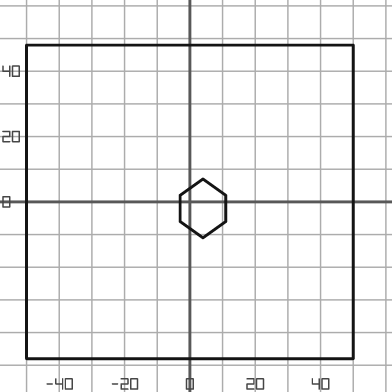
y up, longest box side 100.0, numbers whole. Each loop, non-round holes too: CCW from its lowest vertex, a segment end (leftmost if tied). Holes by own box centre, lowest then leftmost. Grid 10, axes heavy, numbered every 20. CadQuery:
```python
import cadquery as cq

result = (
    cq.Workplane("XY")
    .moveTo(-50.0, -48.0)
    .lineTo(50.0, -48.0)
    .lineTo(50.0, 48.0)
    .lineTo(-50.0, 48.0)
    .close()
    .moveTo(4.0, -11.0)
    .lineTo(11.0, -6.0)
    .lineTo(11.0, 2.0)
    .lineTo(4.0, 7.0)
    .lineTo(-3.0, 2.0)
    .lineTo(-3.0, -6.0)
    .close()
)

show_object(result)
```